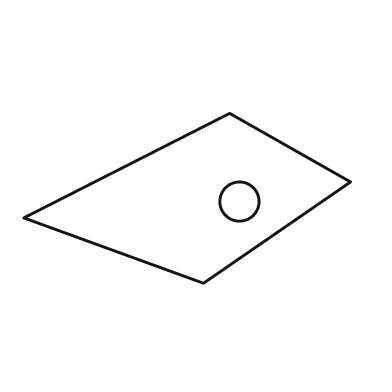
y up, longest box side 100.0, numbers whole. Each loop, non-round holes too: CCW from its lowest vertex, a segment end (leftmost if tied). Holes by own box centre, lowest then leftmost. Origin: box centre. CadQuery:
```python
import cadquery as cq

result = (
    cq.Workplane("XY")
    .moveTo(5.0, -26.0)
    .lineTo(50.0, 5.0)
    .lineTo(13.0, 26.0)
    .lineTo(-50.0, -6.0)
    .close()
    .moveTo(16.0, -1.0)
    .circle(6.0)
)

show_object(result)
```